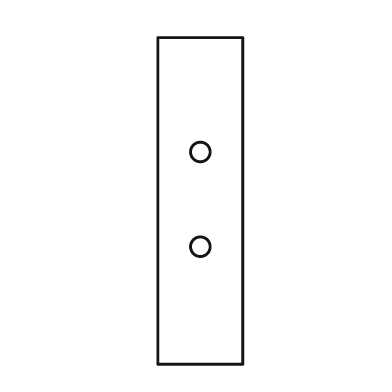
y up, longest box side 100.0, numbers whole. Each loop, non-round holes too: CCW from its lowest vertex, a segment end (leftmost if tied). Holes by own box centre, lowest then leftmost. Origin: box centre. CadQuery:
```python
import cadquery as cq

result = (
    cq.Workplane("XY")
    .moveTo(-13.0, -50.0)
    .lineTo(13.0, -50.0)
    .lineTo(13.0, 50.0)
    .lineTo(-13.0, 50.0)
    .close()
    .moveTo(0.0, -14.0)
    .circle(3.0)
    .moveTo(0.0, 15.0)
    .circle(3.0)
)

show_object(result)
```